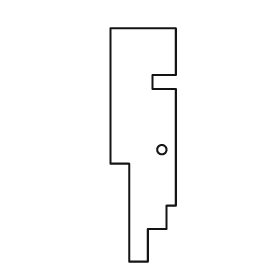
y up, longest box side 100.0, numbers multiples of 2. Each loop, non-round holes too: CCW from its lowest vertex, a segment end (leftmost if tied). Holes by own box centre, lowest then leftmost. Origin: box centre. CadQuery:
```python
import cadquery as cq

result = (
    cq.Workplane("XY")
    .moveTo(-6.0, -50.0)
    .lineTo(2.0, -50.0)
    .lineTo(2.0, -36.0)
    .lineTo(10.0, -36.0)
    .lineTo(10.0, -26.0)
    .lineTo(14.0, -26.0)
    .lineTo(14.0, 24.0)
    .lineTo(4.0, 24.0)
    .lineTo(4.0, 30.0)
    .lineTo(14.0, 30.0)
    .lineTo(14.0, 50.0)
    .lineTo(-14.0, 50.0)
    .lineTo(-14.0, -8.0)
    .lineTo(-6.0, -8.0)
    .close()
    .moveTo(8.0, -2.0)
    .circle(2.0)
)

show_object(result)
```